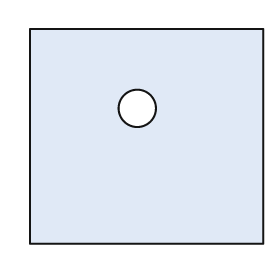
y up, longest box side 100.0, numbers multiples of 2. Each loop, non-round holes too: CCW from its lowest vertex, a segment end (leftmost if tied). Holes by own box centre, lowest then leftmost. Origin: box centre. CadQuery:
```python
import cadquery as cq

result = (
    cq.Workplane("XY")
    .moveTo(-50.0, -46.0)
    .lineTo(50.0, -46.0)
    .lineTo(50.0, 46.0)
    .lineTo(-50.0, 46.0)
    .close()
    .moveTo(-4.0, 12.0)
    .circle(8.0)
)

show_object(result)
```